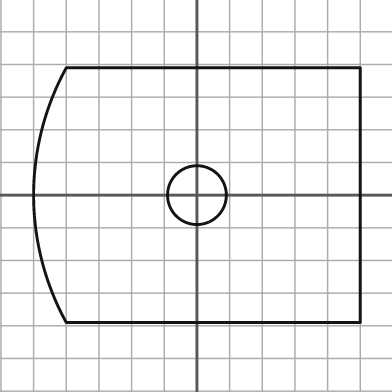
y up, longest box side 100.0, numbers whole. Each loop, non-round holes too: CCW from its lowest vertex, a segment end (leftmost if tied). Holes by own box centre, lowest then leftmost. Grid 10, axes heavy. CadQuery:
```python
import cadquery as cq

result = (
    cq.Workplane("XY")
    .moveTo(-40.0, -39.0)
    .lineTo(50.0, -39.0)
    .lineTo(50.0, 39.0)
    .lineTo(-40.0, 39.0)
    .threePointArc((-50.0, 0.0), (-40.0, -39.0))
    .close()
    .moveTo(0.0, 0.0)
    .circle(9.0)
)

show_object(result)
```